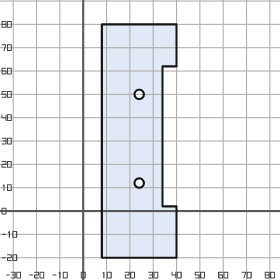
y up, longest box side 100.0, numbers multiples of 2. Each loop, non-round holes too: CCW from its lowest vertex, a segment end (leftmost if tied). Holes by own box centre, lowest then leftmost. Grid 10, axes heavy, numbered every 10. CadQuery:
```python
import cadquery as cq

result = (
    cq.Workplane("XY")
    .moveTo(8.0, -20.0)
    .lineTo(40.0, -20.0)
    .lineTo(40.0, 2.0)
    .lineTo(34.0, 2.0)
    .lineTo(34.0, 62.0)
    .lineTo(40.0, 62.0)
    .lineTo(40.0, 80.0)
    .lineTo(8.0, 80.0)
    .close()
    .moveTo(24.0, 12.0)
    .circle(2.0)
    .moveTo(24.0, 50.0)
    .circle(2.0)
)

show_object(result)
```